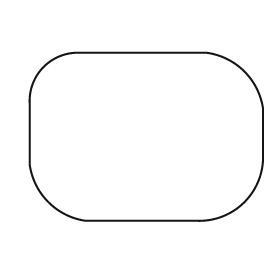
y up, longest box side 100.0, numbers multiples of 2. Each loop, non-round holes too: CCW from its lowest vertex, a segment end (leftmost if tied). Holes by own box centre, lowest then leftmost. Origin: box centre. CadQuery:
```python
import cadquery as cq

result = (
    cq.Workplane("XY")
    .moveTo(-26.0, -36.0)
    .lineTo(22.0, -36.0)
    .threePointArc((42.0, -28.0), (50.0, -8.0))
    .lineTo(50.0, 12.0)
    .threePointArc((42.0, 28.0), (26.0, 36.0))
    .lineTo(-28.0, 36.0)
    .threePointArc((-44.0, 30.0), (-50.0, 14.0))
    .lineTo(-50.0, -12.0)
    .threePointArc((-42.0, -28.0), (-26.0, -36.0))
    .close()
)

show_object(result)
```